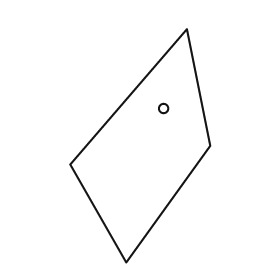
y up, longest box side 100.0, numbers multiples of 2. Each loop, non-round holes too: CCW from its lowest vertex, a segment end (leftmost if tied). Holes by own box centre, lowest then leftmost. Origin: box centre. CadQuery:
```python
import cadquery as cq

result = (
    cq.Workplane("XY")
    .moveTo(-6.0, -50.0)
    .lineTo(30.0, 0.0)
    .lineTo(20.0, 50.0)
    .lineTo(-30.0, -8.0)
    .close()
    .moveTo(10.0, 16.0)
    .circle(2.0)
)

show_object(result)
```